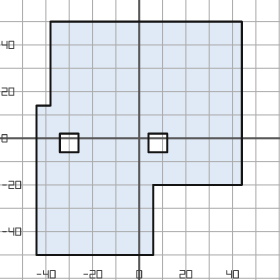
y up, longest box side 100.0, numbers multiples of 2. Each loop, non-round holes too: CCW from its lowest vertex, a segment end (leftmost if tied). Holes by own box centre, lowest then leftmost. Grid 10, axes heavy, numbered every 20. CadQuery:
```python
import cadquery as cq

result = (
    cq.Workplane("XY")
    .moveTo(-44.0, -50.0)
    .lineTo(6.0, -50.0)
    .lineTo(6.0, -20.0)
    .lineTo(44.0, -20.0)
    .lineTo(44.0, 50.0)
    .lineTo(-38.0, 50.0)
    .lineTo(-38.0, 14.0)
    .lineTo(-44.0, 14.0)
    .close()
    .moveTo(-34.0, -6.0)
    .lineTo(-26.0, -6.0)
    .lineTo(-26.0, 2.0)
    .lineTo(-34.0, 2.0)
    .close()
    .moveTo(4.0, -6.0)
    .lineTo(12.0, -6.0)
    .lineTo(12.0, 2.0)
    .lineTo(4.0, 2.0)
    .close()
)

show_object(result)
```